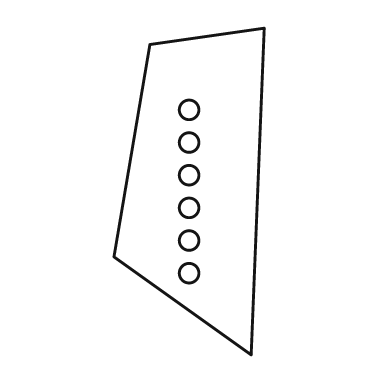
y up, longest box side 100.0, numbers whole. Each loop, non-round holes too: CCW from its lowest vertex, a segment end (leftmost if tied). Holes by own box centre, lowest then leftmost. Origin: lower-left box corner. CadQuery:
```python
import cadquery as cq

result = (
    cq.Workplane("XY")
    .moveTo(42.0, 0.0)
    .lineTo(46.0, 100.0)
    .lineTo(11.0, 95.0)
    .lineTo(0.0, 30.0)
    .close()
    .moveTo(23.0, 25.0)
    .circle(3.0)
    .moveTo(23.0, 35.0)
    .circle(3.0)
    .moveTo(23.0, 45.0)
    .circle(3.0)
    .moveTo(23.0, 55.0)
    .circle(3.0)
    .moveTo(23.0, 65.0)
    .circle(3.0)
    .moveTo(23.0, 75.0)
    .circle(3.0)
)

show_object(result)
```